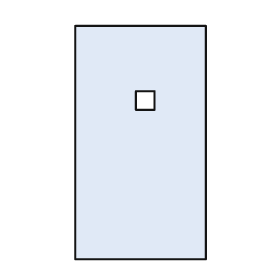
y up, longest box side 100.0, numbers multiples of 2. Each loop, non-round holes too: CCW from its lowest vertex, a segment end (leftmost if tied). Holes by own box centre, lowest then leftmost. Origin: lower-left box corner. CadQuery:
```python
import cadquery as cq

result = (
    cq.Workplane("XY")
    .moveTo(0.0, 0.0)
    .lineTo(56.0, 0.0)
    .lineTo(56.0, 100.0)
    .lineTo(0.0, 100.0)
    .close()
    .moveTo(26.0, 64.0)
    .lineTo(34.0, 64.0)
    .lineTo(34.0, 72.0)
    .lineTo(26.0, 72.0)
    .close()
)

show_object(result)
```